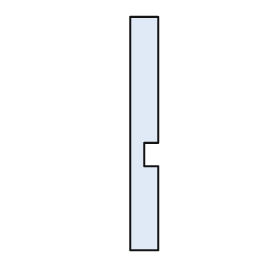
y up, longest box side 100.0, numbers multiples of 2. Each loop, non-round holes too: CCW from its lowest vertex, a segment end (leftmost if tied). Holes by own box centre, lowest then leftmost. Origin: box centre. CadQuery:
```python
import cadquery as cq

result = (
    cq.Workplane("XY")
    .moveTo(-6.0, -50.0)
    .lineTo(6.0, -50.0)
    .lineTo(6.0, -14.0)
    .lineTo(0.0, -14.0)
    .lineTo(0.0, -4.0)
    .lineTo(6.0, -4.0)
    .lineTo(6.0, 50.0)
    .lineTo(-6.0, 50.0)
    .close()
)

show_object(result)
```